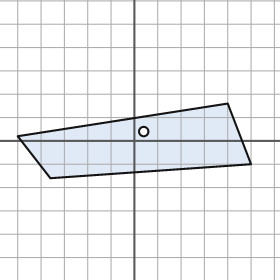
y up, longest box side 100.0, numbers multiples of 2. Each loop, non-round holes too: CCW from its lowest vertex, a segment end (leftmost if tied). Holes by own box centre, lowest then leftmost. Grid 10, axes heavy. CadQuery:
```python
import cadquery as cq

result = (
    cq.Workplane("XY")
    .moveTo(-36.0, -16.0)
    .lineTo(50.0, -10.0)
    .lineTo(40.0, 16.0)
    .lineTo(-50.0, 2.0)
    .close()
    .moveTo(4.0, 4.0)
    .circle(2.0)
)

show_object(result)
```